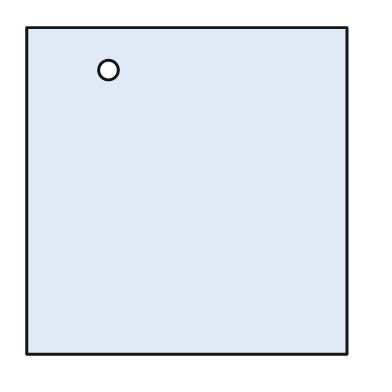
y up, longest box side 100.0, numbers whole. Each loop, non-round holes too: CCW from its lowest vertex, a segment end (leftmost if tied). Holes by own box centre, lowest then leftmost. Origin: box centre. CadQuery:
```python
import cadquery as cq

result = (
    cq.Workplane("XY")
    .moveTo(-49.0, -50.0)
    .lineTo(49.0, -50.0)
    .lineTo(49.0, 50.0)
    .lineTo(-49.0, 50.0)
    .close()
    .moveTo(-24.0, 37.0)
    .circle(3.0)
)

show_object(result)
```